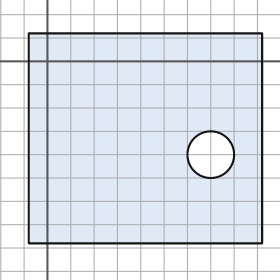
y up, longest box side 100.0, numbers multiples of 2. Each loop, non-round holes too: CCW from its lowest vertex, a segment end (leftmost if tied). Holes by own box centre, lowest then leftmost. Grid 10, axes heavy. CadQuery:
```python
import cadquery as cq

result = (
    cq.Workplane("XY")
    .moveTo(-8.0, -78.0)
    .lineTo(92.0, -78.0)
    .lineTo(92.0, 12.0)
    .lineTo(-8.0, 12.0)
    .close()
    .moveTo(70.0, -40.0)
    .circle(10.0)
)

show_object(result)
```